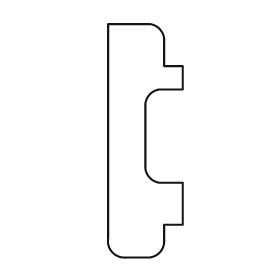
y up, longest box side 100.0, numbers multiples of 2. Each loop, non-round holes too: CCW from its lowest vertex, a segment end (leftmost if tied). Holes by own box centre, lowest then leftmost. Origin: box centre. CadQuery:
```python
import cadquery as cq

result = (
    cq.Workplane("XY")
    .moveTo(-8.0, -50.0)
    .lineTo(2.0, -50.0)
    .threePointArc((6.0, -48.0), (8.0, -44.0))
    .lineTo(8.0, -36.0)
    .lineTo(16.0, -36.0)
    .lineTo(16.0, -18.0)
    .lineTo(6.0, -18.0)
    .threePointArc((2.0, -16.0), (0.0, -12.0))
    .lineTo(0.0, 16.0)
    .threePointArc((2.0, 20.0), (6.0, 22.0))
    .lineTo(16.0, 22.0)
    .lineTo(16.0, 32.0)
    .lineTo(8.0, 32.0)
    .lineTo(8.0, 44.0)
    .threePointArc((6.0, 48.0), (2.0, 50.0))
    .lineTo(-16.0, 50.0)
    .lineTo(-16.0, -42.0)
    .threePointArc((-14.0, -48.0), (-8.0, -50.0))
    .close()
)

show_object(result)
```